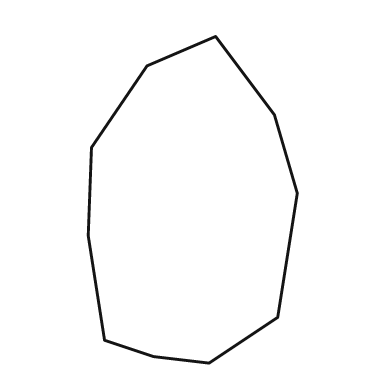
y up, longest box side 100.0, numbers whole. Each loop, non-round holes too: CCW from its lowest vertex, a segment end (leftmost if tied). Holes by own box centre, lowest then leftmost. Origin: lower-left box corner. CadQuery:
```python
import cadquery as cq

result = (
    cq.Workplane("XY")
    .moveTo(37.0, 0.0)
    .lineTo(58.0, 14.0)
    .lineTo(64.0, 52.0)
    .lineTo(57.0, 76.0)
    .lineTo(39.0, 100.0)
    .lineTo(18.0, 91.0)
    .lineTo(1.0, 66.0)
    .lineTo(0.0, 39.0)
    .lineTo(5.0, 7.0)
    .lineTo(20.0, 2.0)
    .close()
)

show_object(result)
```